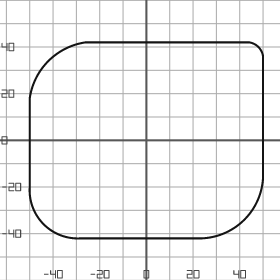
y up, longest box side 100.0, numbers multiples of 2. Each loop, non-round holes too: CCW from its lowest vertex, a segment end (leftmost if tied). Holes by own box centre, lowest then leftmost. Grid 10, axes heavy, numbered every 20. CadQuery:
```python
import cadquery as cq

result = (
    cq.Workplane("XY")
    .moveTo(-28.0, -42.0)
    .lineTo(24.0, -42.0)
    .threePointArc((42.0, -34.0), (50.0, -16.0))
    .lineTo(50.0, 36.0)
    .threePointArc((48.0, 40.0), (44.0, 42.0))
    .lineTo(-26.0, 42.0)
    .threePointArc((-42.0, 34.0), (-50.0, 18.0))
    .lineTo(-50.0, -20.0)
    .threePointArc((-44.0, -36.0), (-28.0, -42.0))
    .close()
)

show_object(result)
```